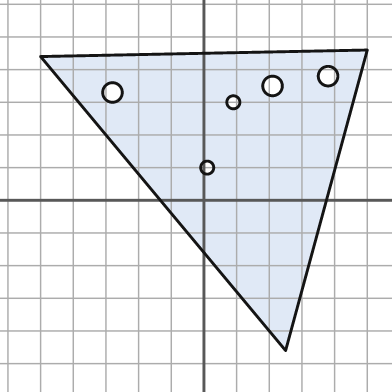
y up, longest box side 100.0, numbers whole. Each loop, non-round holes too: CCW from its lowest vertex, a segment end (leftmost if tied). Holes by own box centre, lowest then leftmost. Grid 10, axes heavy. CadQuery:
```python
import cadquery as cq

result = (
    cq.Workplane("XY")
    .moveTo(25.0, -46.0)
    .lineTo(50.0, 46.0)
    .lineTo(-50.0, 44.0)
    .close()
    .moveTo(1.0, 10.0)
    .circle(2.0)
    .moveTo(9.0, 30.0)
    .circle(2.0)
    .moveTo(-28.0, 33.0)
    .circle(3.0)
    .moveTo(21.0, 35.0)
    .circle(3.0)
    .moveTo(38.0, 38.0)
    .circle(3.0)
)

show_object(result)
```